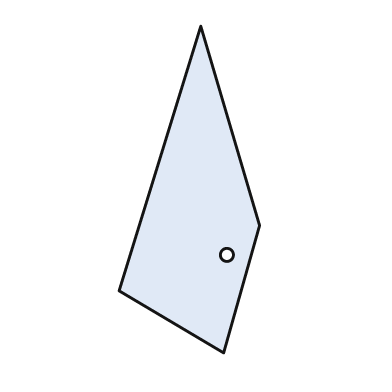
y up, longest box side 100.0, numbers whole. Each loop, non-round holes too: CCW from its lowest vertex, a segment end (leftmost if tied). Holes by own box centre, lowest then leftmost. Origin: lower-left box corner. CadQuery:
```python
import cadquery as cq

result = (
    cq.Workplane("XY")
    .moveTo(32.0, 0.0)
    .lineTo(43.0, 39.0)
    .lineTo(25.0, 100.0)
    .lineTo(0.0, 19.0)
    .close()
    .moveTo(33.0, 30.0)
    .circle(2.0)
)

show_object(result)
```